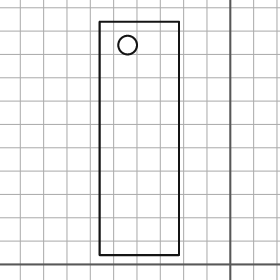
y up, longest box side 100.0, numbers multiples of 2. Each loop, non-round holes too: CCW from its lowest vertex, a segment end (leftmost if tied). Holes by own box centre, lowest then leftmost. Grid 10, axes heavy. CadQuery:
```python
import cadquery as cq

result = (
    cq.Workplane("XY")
    .moveTo(-56.0, 4.0)
    .lineTo(-22.0, 4.0)
    .lineTo(-22.0, 104.0)
    .lineTo(-56.0, 104.0)
    .close()
    .moveTo(-44.0, 94.0)
    .circle(4.0)
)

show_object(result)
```